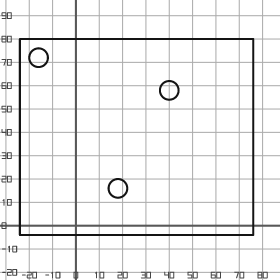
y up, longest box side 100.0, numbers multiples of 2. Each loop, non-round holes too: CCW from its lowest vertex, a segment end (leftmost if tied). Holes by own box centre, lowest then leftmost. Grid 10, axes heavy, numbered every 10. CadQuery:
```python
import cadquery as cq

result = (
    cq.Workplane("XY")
    .moveTo(-24.0, -4.0)
    .lineTo(76.0, -4.0)
    .lineTo(76.0, 80.0)
    .lineTo(-24.0, 80.0)
    .close()
    .moveTo(18.0, 16.0)
    .circle(4.0)
    .moveTo(40.0, 58.0)
    .circle(4.0)
    .moveTo(-16.0, 72.0)
    .circle(4.0)
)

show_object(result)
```